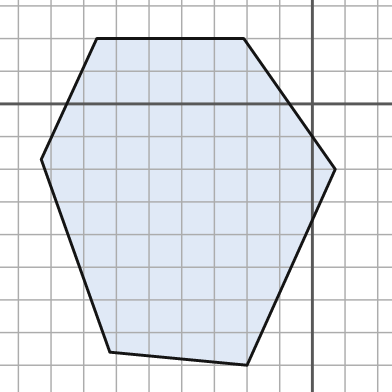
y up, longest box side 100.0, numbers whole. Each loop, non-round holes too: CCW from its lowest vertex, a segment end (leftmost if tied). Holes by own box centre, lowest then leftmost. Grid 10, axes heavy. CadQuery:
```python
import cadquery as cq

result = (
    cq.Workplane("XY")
    .moveTo(-20.0, -80.0)
    .lineTo(7.0, -20.0)
    .lineTo(-21.0, 20.0)
    .lineTo(-66.0, 20.0)
    .lineTo(-83.0, -17.0)
    .lineTo(-62.0, -76.0)
    .close()
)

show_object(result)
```